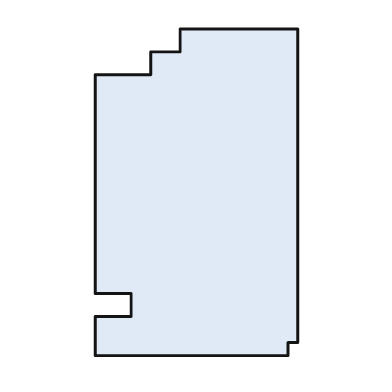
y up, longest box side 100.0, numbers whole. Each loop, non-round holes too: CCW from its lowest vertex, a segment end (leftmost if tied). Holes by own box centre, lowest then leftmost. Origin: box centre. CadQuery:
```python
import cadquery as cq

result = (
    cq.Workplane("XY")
    .moveTo(-31.0, -50.0)
    .lineTo(28.0, -50.0)
    .lineTo(28.0, -46.0)
    .lineTo(31.0, -46.0)
    .lineTo(31.0, 50.0)
    .lineTo(-5.0, 50.0)
    .lineTo(-5.0, 43.0)
    .lineTo(-14.0, 43.0)
    .lineTo(-14.0, 36.0)
    .lineTo(-31.0, 36.0)
    .lineTo(-31.0, -31.0)
    .lineTo(-20.0, -31.0)
    .lineTo(-20.0, -38.0)
    .lineTo(-31.0, -38.0)
    .close()
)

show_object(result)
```